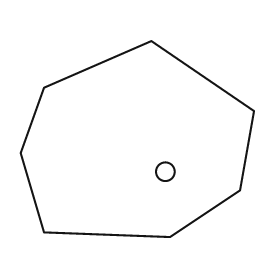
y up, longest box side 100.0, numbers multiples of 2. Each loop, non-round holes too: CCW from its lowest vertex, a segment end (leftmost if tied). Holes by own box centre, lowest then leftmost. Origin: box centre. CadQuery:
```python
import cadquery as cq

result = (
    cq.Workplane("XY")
    .moveTo(14.0, -42.0)
    .lineTo(44.0, -22.0)
    .lineTo(50.0, 12.0)
    .lineTo(6.0, 42.0)
    .lineTo(-40.0, 22.0)
    .lineTo(-50.0, -6.0)
    .lineTo(-40.0, -40.0)
    .close()
    .moveTo(12.0, -14.0)
    .circle(4.0)
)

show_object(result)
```